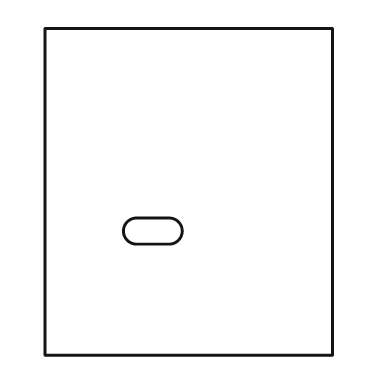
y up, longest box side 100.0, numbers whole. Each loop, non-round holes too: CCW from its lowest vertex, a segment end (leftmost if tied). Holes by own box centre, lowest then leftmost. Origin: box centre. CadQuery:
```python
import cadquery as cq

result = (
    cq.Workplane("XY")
    .moveTo(-44.0, -50.0)
    .lineTo(44.0, -50.0)
    .lineTo(44.0, 50.0)
    .lineTo(-44.0, 50.0)
    .close()
    .moveTo(-16.0, -16.0)
    .lineTo(-6.0, -16.0)
    .threePointArc((-2.0, -12.0), (-6.0, -8.0))
    .lineTo(-16.0, -8.0)
    .threePointArc((-20.0, -12.0), (-16.0, -16.0))
    .close()
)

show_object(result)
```